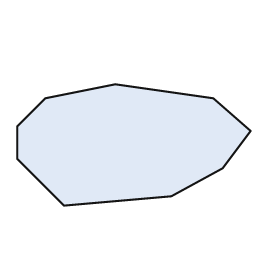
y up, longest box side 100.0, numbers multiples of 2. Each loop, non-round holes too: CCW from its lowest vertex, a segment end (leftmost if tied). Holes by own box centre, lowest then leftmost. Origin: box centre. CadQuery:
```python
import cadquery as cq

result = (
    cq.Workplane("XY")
    .moveTo(-30.0, -26.0)
    .lineTo(16.0, -22.0)
    .lineTo(38.0, -10.0)
    .lineTo(50.0, 6.0)
    .lineTo(34.0, 20.0)
    .lineTo(-8.0, 26.0)
    .lineTo(-38.0, 20.0)
    .lineTo(-50.0, 8.0)
    .lineTo(-50.0, -6.0)
    .close()
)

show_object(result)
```